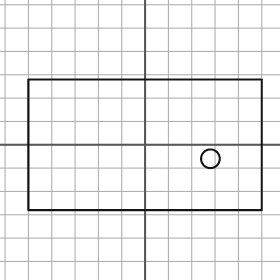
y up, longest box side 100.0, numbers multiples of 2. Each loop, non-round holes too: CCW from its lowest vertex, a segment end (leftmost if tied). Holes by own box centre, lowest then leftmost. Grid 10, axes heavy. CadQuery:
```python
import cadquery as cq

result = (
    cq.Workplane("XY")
    .moveTo(-50.0, -28.0)
    .lineTo(50.0, -28.0)
    .lineTo(50.0, 28.0)
    .lineTo(-50.0, 28.0)
    .close()
    .moveTo(28.0, -6.0)
    .circle(4.0)
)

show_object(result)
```